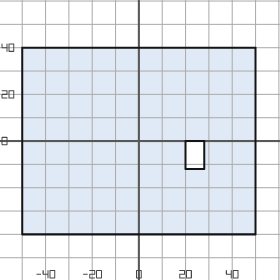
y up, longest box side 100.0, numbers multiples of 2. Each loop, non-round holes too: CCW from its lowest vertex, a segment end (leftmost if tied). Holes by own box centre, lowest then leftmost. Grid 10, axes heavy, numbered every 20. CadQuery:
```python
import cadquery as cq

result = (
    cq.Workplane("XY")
    .moveTo(-50.0, -40.0)
    .lineTo(50.0, -40.0)
    .lineTo(50.0, 40.0)
    .lineTo(-50.0, 40.0)
    .close()
    .moveTo(20.0, -12.0)
    .lineTo(28.0, -12.0)
    .lineTo(28.0, 0.0)
    .lineTo(20.0, 0.0)
    .close()
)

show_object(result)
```